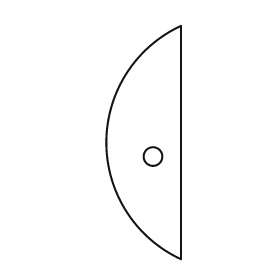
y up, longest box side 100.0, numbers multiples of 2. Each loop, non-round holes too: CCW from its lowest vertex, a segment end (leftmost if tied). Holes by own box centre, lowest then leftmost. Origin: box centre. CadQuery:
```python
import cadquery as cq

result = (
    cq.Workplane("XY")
    .moveTo(16.0, -50.0)
    .lineTo(16.0, 50.0)
    .threePointArc((-16.0, 0.0), (16.0, -50.0))
    .close()
    .moveTo(4.0, -6.0)
    .circle(4.0)
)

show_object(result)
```